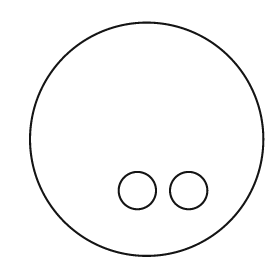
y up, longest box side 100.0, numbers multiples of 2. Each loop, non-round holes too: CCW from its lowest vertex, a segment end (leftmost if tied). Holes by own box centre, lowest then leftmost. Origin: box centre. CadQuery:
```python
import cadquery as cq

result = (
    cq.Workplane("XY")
    .moveTo(0.0, 0.0)
    .circle(50.0)
    .moveTo(-4.0, -22.0)
    .circle(8.0)
    .moveTo(18.0, -22.0)
    .circle(8.0)
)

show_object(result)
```